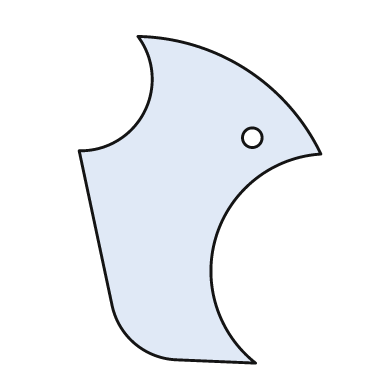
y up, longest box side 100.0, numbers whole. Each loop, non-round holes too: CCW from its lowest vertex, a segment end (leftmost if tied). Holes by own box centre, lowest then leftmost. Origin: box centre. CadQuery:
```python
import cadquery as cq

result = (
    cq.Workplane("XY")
    .moveTo(17.0, -50.0)
    .threePointArc((5.0, -11.0), (37.0, 14.0))
    .threePointArc((14.0, 40.0), (-19.0, 50.0))
    .threePointArc((-17.0, 27.0), (-37.0, 15.0))
    .lineTo(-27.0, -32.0)
    .threePointArc((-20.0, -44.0), (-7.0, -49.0))
    .close()
    .moveTo(16.0, 19.0)
    .circle(3.0)
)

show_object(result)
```